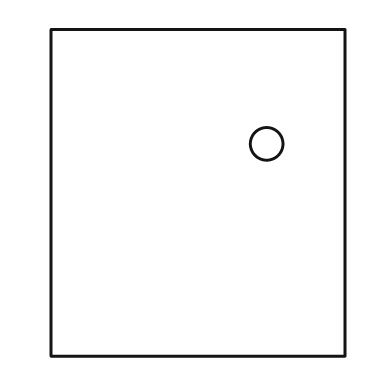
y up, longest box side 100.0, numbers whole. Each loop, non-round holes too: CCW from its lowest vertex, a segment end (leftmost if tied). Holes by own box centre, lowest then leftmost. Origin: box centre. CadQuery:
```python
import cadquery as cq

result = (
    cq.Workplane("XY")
    .moveTo(-45.0, -50.0)
    .lineTo(45.0, -50.0)
    .lineTo(45.0, 50.0)
    .lineTo(-45.0, 50.0)
    .close()
    .moveTo(21.0, 15.0)
    .circle(5.0)
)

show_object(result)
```